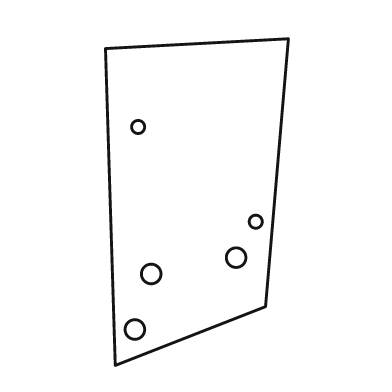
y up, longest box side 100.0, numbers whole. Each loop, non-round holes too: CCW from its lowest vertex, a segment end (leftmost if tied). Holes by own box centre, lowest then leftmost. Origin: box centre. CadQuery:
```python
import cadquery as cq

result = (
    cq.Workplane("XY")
    .moveTo(-25.0, -50.0)
    .lineTo(21.0, -32.0)
    .lineTo(28.0, 50.0)
    .lineTo(-28.0, 47.0)
    .close()
    .moveTo(-19.0, -39.0)
    .circle(3.0)
    .moveTo(-14.0, -22.0)
    .circle(3.0)
    .moveTo(12.0, -17.0)
    .circle(3.0)
    .moveTo(18.0, -6.0)
    .circle(2.0)
    .moveTo(-18.0, 23.0)
    .circle(2.0)
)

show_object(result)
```